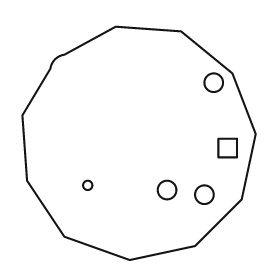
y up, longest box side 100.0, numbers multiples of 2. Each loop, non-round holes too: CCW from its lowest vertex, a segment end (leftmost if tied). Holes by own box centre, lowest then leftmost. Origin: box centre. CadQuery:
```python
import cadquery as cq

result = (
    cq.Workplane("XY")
    .moveTo(-4.0, -50.0)
    .lineTo(24.0, -44.0)
    .lineTo(44.0, -24.0)
    .lineTo(50.0, 4.0)
    .lineTo(40.0, 30.0)
    .lineTo(18.0, 48.0)
    .lineTo(-10.0, 50.0)
    .lineTo(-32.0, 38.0)
    .threePointArc((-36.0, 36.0), (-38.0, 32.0))
    .lineTo(-50.0, 12.0)
    .lineTo(-48.0, -16.0)
    .lineTo(-32.0, -40.0)
    .close()
    .moveTo(28.0, -22.0)
    .circle(4.0)
    .moveTo(12.0, -20.0)
    .circle(4.0)
    .moveTo(-22.0, -18.0)
    .circle(2.0)
    .moveTo(34.0, -6.0)
    .lineTo(42.0, -6.0)
    .lineTo(42.0, 2.0)
    .lineTo(34.0, 2.0)
    .close()
    .moveTo(32.0, 26.0)
    .circle(4.0)
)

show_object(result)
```